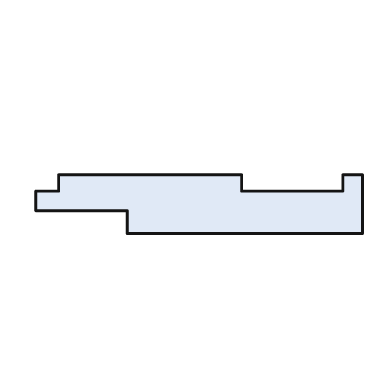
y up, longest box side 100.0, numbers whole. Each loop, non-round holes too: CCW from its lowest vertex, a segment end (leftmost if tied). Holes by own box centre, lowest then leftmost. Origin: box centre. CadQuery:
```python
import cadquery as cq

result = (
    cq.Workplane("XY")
    .moveTo(-22.0, -9.0)
    .lineTo(50.0, -9.0)
    .lineTo(50.0, 9.0)
    .lineTo(44.0, 9.0)
    .lineTo(44.0, 4.0)
    .lineTo(13.0, 4.0)
    .lineTo(13.0, 9.0)
    .lineTo(-43.0, 9.0)
    .lineTo(-43.0, 4.0)
    .lineTo(-50.0, 4.0)
    .lineTo(-50.0, -2.0)
    .lineTo(-22.0, -2.0)
    .close()
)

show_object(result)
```